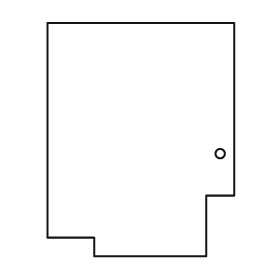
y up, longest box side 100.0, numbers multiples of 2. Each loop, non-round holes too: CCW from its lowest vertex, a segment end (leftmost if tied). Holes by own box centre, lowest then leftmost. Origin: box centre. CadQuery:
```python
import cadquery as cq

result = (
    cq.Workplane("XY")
    .moveTo(-20.0, -50.0)
    .lineTo(28.0, -50.0)
    .lineTo(28.0, -24.0)
    .lineTo(40.0, -24.0)
    .lineTo(40.0, 50.0)
    .lineTo(-40.0, 50.0)
    .lineTo(-40.0, -42.0)
    .lineTo(-20.0, -42.0)
    .close()
    .moveTo(34.0, -6.0)
    .circle(2.0)
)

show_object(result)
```